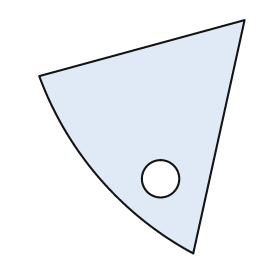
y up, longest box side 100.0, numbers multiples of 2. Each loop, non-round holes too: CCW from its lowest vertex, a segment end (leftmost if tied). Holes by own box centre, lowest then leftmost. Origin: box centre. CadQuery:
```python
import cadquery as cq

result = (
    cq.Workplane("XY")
    .moveTo(22.0, -50.0)
    .lineTo(44.0, 50.0)
    .lineTo(-44.0, 26.0)
    .threePointArc((-18.0, -18.0), (22.0, -50.0))
    .close()
    .moveTo(8.0, -18.0)
    .circle(8.0)
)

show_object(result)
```